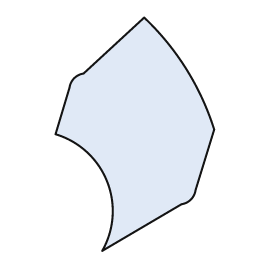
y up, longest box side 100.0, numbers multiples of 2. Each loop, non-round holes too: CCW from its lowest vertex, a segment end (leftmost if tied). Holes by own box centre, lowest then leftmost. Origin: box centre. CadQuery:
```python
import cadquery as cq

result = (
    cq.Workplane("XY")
    .moveTo(-14.0, -50.0)
    .lineTo(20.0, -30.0)
    .threePointArc((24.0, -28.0), (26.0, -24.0))
    .lineTo(34.0, 2.0)
    .threePointArc((22.0, 28.0), (4.0, 50.0))
    .lineTo(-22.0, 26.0)
    .threePointArc((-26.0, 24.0), (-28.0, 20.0))
    .lineTo(-34.0, 0.0)
    .threePointArc((-12.0, -20.0), (-14.0, -50.0))
    .close()
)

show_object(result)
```